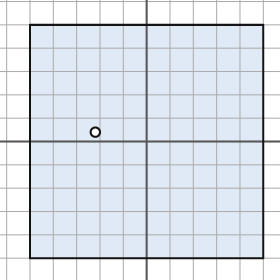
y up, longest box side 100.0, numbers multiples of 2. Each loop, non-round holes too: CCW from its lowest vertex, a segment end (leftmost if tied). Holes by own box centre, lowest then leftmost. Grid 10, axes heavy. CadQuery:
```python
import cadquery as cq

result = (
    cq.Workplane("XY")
    .moveTo(-50.0, -50.0)
    .lineTo(50.0, -50.0)
    .lineTo(50.0, 50.0)
    .lineTo(-50.0, 50.0)
    .close()
    .moveTo(-22.0, 4.0)
    .circle(2.0)
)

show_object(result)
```